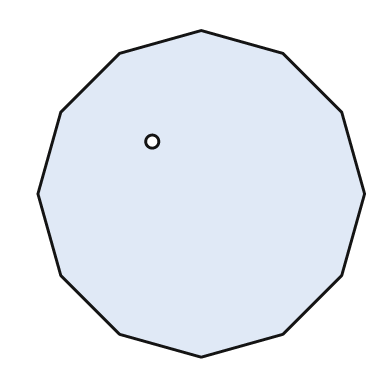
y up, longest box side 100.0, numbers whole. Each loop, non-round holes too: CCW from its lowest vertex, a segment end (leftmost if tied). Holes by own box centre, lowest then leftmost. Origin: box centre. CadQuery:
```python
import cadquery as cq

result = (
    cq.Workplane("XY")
    .moveTo(0.0, -50.0)
    .lineTo(25.0, -43.0)
    .lineTo(43.0, -25.0)
    .lineTo(50.0, 0.0)
    .lineTo(43.0, 25.0)
    .lineTo(25.0, 43.0)
    .lineTo(0.0, 50.0)
    .lineTo(-25.0, 43.0)
    .lineTo(-43.0, 25.0)
    .lineTo(-50.0, 0.0)
    .lineTo(-43.0, -25.0)
    .lineTo(-25.0, -43.0)
    .close()
    .moveTo(-15.0, 16.0)
    .circle(2.0)
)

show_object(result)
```